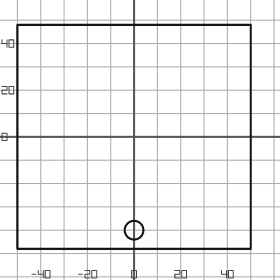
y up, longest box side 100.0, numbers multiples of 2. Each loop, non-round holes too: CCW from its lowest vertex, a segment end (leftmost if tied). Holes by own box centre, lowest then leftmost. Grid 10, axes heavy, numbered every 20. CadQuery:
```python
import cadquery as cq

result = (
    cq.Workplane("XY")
    .moveTo(-50.0, -48.0)
    .lineTo(50.0, -48.0)
    .lineTo(50.0, 48.0)
    .lineTo(-50.0, 48.0)
    .close()
    .moveTo(0.0, -40.0)
    .circle(4.0)
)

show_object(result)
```